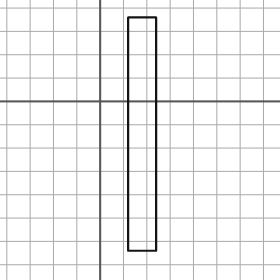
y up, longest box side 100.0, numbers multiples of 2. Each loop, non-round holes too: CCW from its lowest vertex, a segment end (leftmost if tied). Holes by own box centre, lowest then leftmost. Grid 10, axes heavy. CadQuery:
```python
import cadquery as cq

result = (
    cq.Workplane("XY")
    .moveTo(12.0, -64.0)
    .lineTo(24.0, -64.0)
    .lineTo(24.0, 36.0)
    .lineTo(12.0, 36.0)
    .close()
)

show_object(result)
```